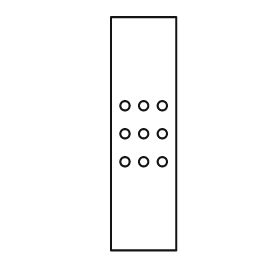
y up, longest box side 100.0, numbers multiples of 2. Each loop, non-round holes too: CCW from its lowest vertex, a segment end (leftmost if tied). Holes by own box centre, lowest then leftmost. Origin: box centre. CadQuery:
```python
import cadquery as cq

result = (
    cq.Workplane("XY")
    .moveTo(-14.0, -50.0)
    .lineTo(14.0, -50.0)
    .lineTo(14.0, 50.0)
    .lineTo(-14.0, 50.0)
    .close()
    .moveTo(-8.0, -12.0)
    .circle(2.0)
    .moveTo(0.0, -12.0)
    .circle(2.0)
    .moveTo(8.0, -12.0)
    .circle(2.0)
    .moveTo(-8.0, 0.0)
    .circle(2.0)
    .moveTo(0.0, 0.0)
    .circle(2.0)
    .moveTo(8.0, 0.0)
    .circle(2.0)
    .moveTo(-8.0, 12.0)
    .circle(2.0)
    .moveTo(0.0, 12.0)
    .circle(2.0)
    .moveTo(8.0, 12.0)
    .circle(2.0)
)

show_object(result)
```